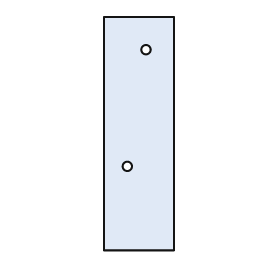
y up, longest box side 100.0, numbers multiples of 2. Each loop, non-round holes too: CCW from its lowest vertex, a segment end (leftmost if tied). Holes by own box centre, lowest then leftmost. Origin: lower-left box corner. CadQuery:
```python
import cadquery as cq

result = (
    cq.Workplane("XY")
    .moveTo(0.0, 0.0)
    .lineTo(30.0, 0.0)
    .lineTo(30.0, 100.0)
    .lineTo(0.0, 100.0)
    .close()
    .moveTo(10.0, 36.0)
    .circle(2.0)
    .moveTo(18.0, 86.0)
    .circle(2.0)
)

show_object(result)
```